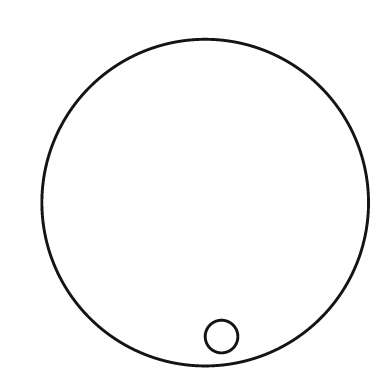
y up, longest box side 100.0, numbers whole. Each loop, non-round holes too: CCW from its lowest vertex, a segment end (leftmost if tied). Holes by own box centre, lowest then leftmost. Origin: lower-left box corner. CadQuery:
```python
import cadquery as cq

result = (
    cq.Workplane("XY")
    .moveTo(50.0, 50.0)
    .circle(50.0)
    .moveTo(55.0, 9.0)
    .circle(5.0)
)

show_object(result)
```